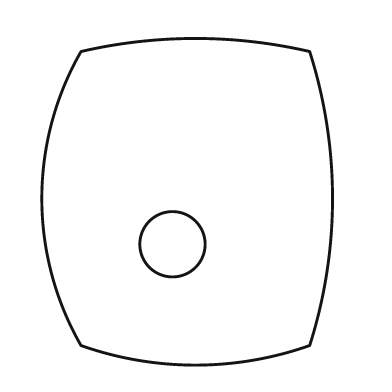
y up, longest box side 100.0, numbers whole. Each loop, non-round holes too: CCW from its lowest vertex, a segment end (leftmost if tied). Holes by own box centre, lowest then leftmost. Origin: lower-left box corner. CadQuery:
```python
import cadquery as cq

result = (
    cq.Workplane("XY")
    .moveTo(12.0, 6.0)
    .threePointArc((47.0, 0.0), (82.0, 6.0))
    .threePointArc((89.0, 51.0), (82.0, 96.0))
    .threePointArc((47.0, 100.0), (12.0, 96.0))
    .threePointArc((0.0, 51.0), (12.0, 6.0))
    .close()
    .moveTo(40.0, 37.0)
    .circle(10.0)
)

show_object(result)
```